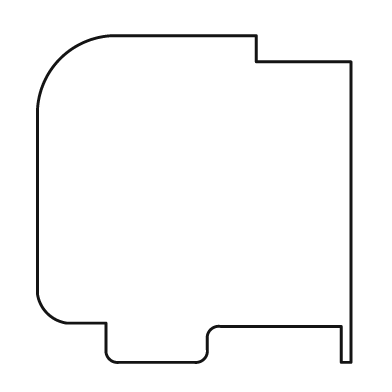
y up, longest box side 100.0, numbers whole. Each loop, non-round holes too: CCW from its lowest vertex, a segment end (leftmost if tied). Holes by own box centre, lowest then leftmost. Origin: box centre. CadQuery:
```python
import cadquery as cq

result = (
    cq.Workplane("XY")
    .moveTo(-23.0, -50.0)
    .lineTo(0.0, -50.0)
    .threePointArc((3.0, -49.0), (4.0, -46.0))
    .lineTo(4.0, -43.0)
    .threePointArc((5.0, -40.0), (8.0, -39.0))
    .lineTo(45.0, -39.0)
    .lineTo(45.0, -50.0)
    .lineTo(48.0, -50.0)
    .lineTo(48.0, 42.0)
    .lineTo(19.0, 42.0)
    .lineTo(19.0, 50.0)
    .lineTo(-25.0, 50.0)
    .threePointArc((-41.0, 43.0), (-48.0, 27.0))
    .lineTo(-48.0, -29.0)
    .threePointArc((-45.0, -35.0), (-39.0, -38.0))
    .lineTo(-27.0, -38.0)
    .lineTo(-27.0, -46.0)
    .threePointArc((-26.0, -49.0), (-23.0, -50.0))
    .close()
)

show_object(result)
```